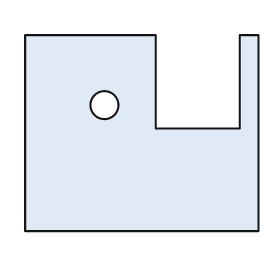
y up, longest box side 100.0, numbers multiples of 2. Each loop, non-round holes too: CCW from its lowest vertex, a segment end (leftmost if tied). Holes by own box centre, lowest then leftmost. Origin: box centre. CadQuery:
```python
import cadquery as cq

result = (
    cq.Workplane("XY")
    .moveTo(-50.0, -42.0)
    .lineTo(50.0, -42.0)
    .lineTo(50.0, 42.0)
    .lineTo(42.0, 42.0)
    .lineTo(42.0, 2.0)
    .lineTo(6.0, 2.0)
    .lineTo(6.0, 42.0)
    .lineTo(-50.0, 42.0)
    .close()
    .moveTo(-16.0, 12.0)
    .circle(6.0)
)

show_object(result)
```